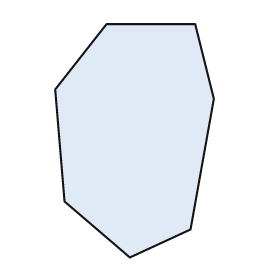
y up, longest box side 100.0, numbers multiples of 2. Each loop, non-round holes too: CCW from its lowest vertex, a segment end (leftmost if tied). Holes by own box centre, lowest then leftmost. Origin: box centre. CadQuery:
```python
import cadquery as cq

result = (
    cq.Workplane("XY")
    .moveTo(-2.0, -50.0)
    .lineTo(24.0, -38.0)
    .lineTo(34.0, 18.0)
    .lineTo(26.0, 50.0)
    .lineTo(-12.0, 50.0)
    .lineTo(-34.0, 22.0)
    .lineTo(-30.0, -26.0)
    .close()
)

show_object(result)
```